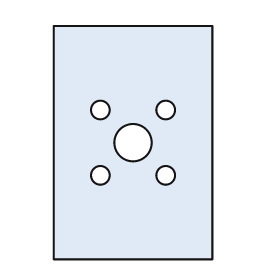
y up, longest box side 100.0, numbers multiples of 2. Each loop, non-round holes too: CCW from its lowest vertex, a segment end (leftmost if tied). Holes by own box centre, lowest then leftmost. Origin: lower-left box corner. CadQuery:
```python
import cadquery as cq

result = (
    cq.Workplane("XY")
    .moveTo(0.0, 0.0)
    .lineTo(68.0, 0.0)
    .lineTo(68.0, 100.0)
    .lineTo(0.0, 100.0)
    .close()
    .moveTo(20.0, 36.0)
    .circle(4.0)
    .moveTo(48.0, 36.0)
    .circle(4.0)
    .moveTo(34.0, 50.0)
    .circle(8.0)
    .moveTo(20.0, 64.0)
    .circle(4.0)
    .moveTo(48.0, 64.0)
    .circle(4.0)
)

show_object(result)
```